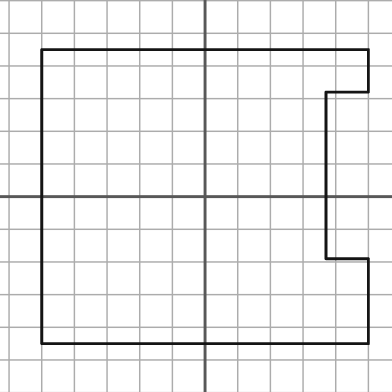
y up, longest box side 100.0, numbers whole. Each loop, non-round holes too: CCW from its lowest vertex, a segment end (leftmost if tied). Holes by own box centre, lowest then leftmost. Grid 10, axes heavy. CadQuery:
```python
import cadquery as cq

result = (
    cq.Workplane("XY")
    .moveTo(-50.0, -45.0)
    .lineTo(50.0, -45.0)
    .lineTo(50.0, -19.0)
    .lineTo(37.0, -19.0)
    .lineTo(37.0, 32.0)
    .lineTo(50.0, 32.0)
    .lineTo(50.0, 45.0)
    .lineTo(-50.0, 45.0)
    .close()
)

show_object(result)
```